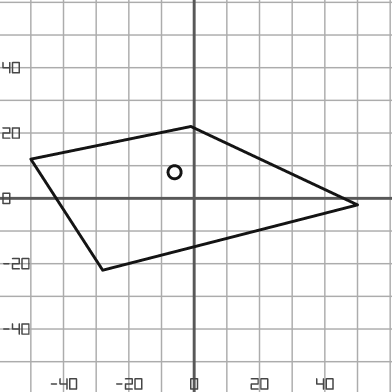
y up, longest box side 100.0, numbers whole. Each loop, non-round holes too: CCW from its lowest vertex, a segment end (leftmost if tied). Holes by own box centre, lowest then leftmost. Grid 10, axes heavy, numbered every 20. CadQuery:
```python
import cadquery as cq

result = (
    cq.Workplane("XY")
    .moveTo(-28.0, -22.0)
    .lineTo(50.0, -2.0)
    .lineTo(-1.0, 22.0)
    .lineTo(-50.0, 12.0)
    .close()
    .moveTo(-6.0, 8.0)
    .circle(2.0)
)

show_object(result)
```